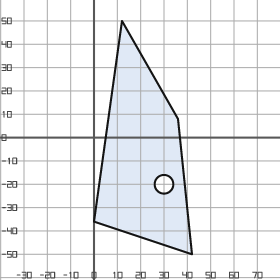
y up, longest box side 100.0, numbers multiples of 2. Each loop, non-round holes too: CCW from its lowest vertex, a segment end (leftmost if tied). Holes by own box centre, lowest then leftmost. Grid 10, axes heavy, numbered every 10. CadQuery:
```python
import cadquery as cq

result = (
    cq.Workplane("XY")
    .moveTo(42.0, -50.0)
    .lineTo(36.0, 8.0)
    .lineTo(12.0, 50.0)
    .lineTo(0.0, -36.0)
    .close()
    .moveTo(30.0, -20.0)
    .circle(4.0)
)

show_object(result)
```